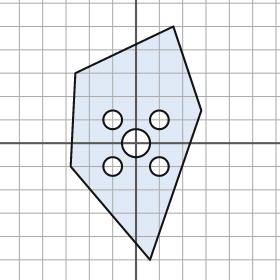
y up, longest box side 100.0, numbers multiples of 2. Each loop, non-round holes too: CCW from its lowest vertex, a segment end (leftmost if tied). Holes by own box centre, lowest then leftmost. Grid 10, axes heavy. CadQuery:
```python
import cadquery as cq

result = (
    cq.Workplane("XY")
    .moveTo(6.0, -50.0)
    .lineTo(28.0, 14.0)
    .lineTo(16.0, 50.0)
    .lineTo(-26.0, 30.0)
    .lineTo(-28.0, -10.0)
    .close()
    .moveTo(-10.0, -10.0)
    .circle(4.0)
    .moveTo(10.0, -10.0)
    .circle(4.0)
    .moveTo(0.0, 0.0)
    .circle(6.0)
    .moveTo(-10.0, 10.0)
    .circle(4.0)
    .moveTo(10.0, 10.0)
    .circle(4.0)
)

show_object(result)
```